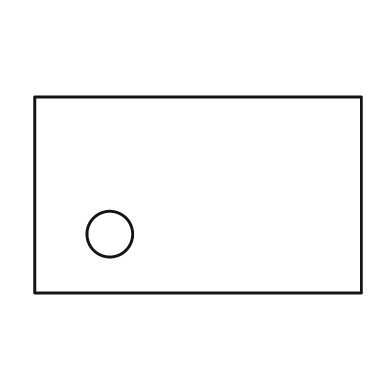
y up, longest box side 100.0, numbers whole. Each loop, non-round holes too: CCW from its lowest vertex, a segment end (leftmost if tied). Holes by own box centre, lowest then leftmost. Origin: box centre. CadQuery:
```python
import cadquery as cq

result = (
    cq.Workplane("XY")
    .moveTo(-50.0, -30.0)
    .lineTo(50.0, -30.0)
    .lineTo(50.0, 30.0)
    .lineTo(-50.0, 30.0)
    .close()
    .moveTo(-27.0, -12.0)
    .circle(7.0)
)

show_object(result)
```